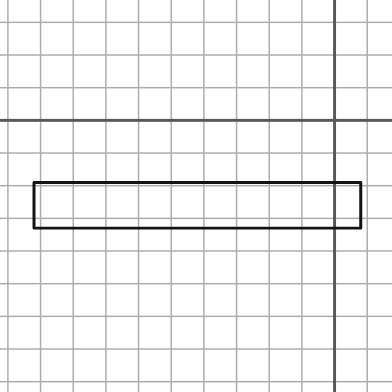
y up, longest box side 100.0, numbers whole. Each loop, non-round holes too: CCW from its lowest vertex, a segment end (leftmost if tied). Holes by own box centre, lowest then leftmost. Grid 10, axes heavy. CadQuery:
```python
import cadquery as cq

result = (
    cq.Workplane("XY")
    .moveTo(-92.0, -33.0)
    .lineTo(8.0, -33.0)
    .lineTo(8.0, -19.0)
    .lineTo(-92.0, -19.0)
    .close()
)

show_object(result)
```